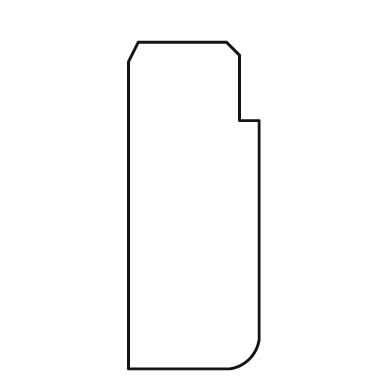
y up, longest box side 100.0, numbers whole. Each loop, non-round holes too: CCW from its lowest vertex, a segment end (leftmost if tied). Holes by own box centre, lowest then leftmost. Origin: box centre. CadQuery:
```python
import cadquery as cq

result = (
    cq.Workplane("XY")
    .moveTo(-20.0, -50.0)
    .lineTo(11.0, -50.0)
    .threePointArc((17.0, -47.0), (20.0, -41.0))
    .lineTo(20.0, 26.0)
    .lineTo(14.0, 26.0)
    .lineTo(14.0, 46.0)
    .lineTo(10.0, 50.0)
    .lineTo(-17.0, 50.0)
    .lineTo(-20.0, 44.0)
    .close()
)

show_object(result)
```